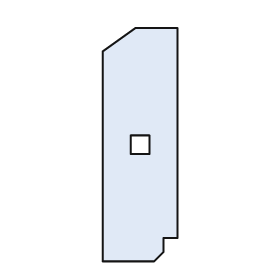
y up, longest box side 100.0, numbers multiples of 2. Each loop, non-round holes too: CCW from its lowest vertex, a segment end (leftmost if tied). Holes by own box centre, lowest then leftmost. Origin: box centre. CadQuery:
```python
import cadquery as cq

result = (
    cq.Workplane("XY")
    .moveTo(-16.0, -50.0)
    .lineTo(6.0, -50.0)
    .lineTo(10.0, -46.0)
    .lineTo(10.0, -40.0)
    .lineTo(16.0, -40.0)
    .lineTo(16.0, 50.0)
    .lineTo(-2.0, 50.0)
    .lineTo(-16.0, 40.0)
    .close()
    .moveTo(-4.0, -4.0)
    .lineTo(4.0, -4.0)
    .lineTo(4.0, 4.0)
    .lineTo(-4.0, 4.0)
    .close()
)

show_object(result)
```